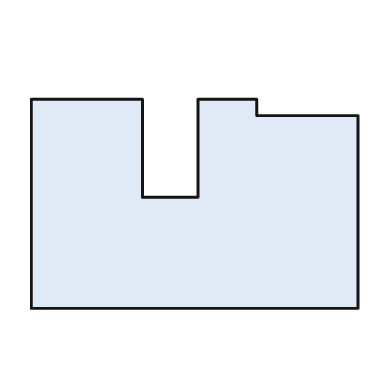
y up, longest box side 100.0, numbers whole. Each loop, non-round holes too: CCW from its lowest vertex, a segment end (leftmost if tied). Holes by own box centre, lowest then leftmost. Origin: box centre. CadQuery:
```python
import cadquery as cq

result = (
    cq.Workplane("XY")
    .moveTo(-50.0, -32.0)
    .lineTo(50.0, -32.0)
    .lineTo(50.0, 27.0)
    .lineTo(19.0, 27.0)
    .lineTo(19.0, 32.0)
    .lineTo(1.0, 32.0)
    .lineTo(1.0, 2.0)
    .lineTo(-16.0, 2.0)
    .lineTo(-16.0, 32.0)
    .lineTo(-50.0, 32.0)
    .close()
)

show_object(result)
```